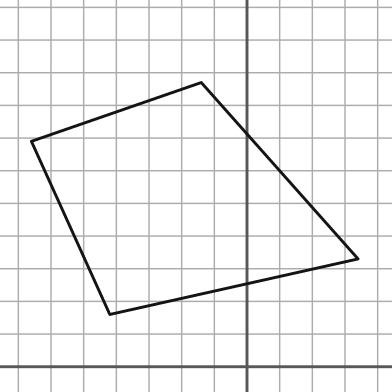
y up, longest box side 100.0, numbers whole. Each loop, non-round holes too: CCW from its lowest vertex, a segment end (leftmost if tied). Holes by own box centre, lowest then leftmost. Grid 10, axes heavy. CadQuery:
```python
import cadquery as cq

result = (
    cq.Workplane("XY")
    .moveTo(-42.0, 16.0)
    .lineTo(34.0, 33.0)
    .lineTo(-14.0, 87.0)
    .lineTo(-66.0, 69.0)
    .close()
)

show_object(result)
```